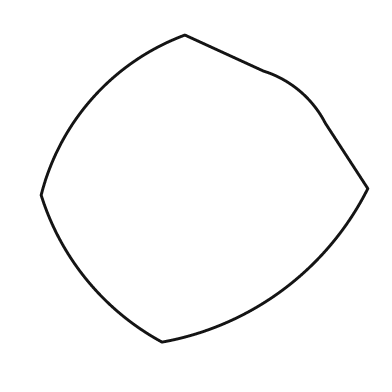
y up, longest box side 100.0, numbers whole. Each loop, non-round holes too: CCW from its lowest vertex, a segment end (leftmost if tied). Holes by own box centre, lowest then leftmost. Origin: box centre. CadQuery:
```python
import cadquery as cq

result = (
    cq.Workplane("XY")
    .moveTo(-13.0, -47.0)
    .threePointArc((24.0, -31.0), (50.0, 0.0))
    .lineTo(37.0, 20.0)
    .threePointArc((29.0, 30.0), (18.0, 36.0))
    .lineTo(-6.0, 47.0)
    .threePointArc((-34.0, 28.0), (-50.0, -2.0))
    .threePointArc((-36.0, -28.0), (-13.0, -47.0))
    .close()
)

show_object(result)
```